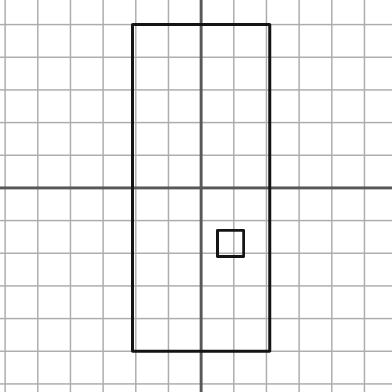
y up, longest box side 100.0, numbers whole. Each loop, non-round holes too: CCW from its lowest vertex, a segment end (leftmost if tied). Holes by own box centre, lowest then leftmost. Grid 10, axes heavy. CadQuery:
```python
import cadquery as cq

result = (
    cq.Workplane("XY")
    .moveTo(-21.0, -50.0)
    .lineTo(21.0, -50.0)
    .lineTo(21.0, 50.0)
    .lineTo(-21.0, 50.0)
    .close()
    .moveTo(5.0, -21.0)
    .lineTo(13.0, -21.0)
    .lineTo(13.0, -13.0)
    .lineTo(5.0, -13.0)
    .close()
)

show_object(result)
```